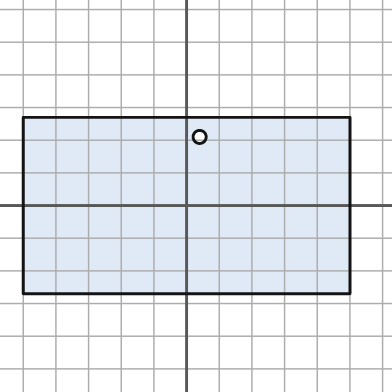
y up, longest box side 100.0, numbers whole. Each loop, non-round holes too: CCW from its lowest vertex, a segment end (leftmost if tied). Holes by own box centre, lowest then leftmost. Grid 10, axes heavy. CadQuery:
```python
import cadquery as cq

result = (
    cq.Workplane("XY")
    .moveTo(-50.0, -27.0)
    .lineTo(50.0, -27.0)
    .lineTo(50.0, 27.0)
    .lineTo(-50.0, 27.0)
    .close()
    .moveTo(4.0, 21.0)
    .circle(2.0)
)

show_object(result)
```